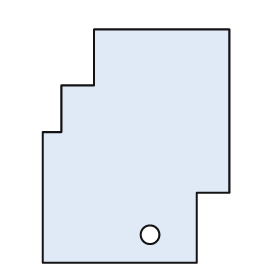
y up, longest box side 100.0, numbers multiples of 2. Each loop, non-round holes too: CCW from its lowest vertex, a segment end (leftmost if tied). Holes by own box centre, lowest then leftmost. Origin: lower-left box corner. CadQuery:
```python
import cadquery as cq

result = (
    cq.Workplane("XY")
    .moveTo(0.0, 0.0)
    .lineTo(66.0, 0.0)
    .lineTo(66.0, 30.0)
    .lineTo(80.0, 30.0)
    .lineTo(80.0, 100.0)
    .lineTo(22.0, 100.0)
    .lineTo(22.0, 76.0)
    .lineTo(8.0, 76.0)
    .lineTo(8.0, 56.0)
    .lineTo(0.0, 56.0)
    .close()
    .moveTo(46.0, 12.0)
    .circle(4.0)
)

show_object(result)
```